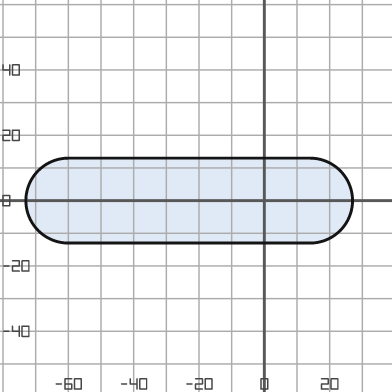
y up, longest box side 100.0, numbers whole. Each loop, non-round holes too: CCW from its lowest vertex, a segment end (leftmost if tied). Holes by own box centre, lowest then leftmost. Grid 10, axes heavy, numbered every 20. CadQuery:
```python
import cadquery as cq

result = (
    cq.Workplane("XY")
    .moveTo(-60.0, -13.0)
    .lineTo(14.0, -13.0)
    .threePointArc((27.0, 0.0), (14.0, 13.0))
    .lineTo(-60.0, 13.0)
    .threePointArc((-73.0, 0.0), (-60.0, -13.0))
    .close()
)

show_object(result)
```